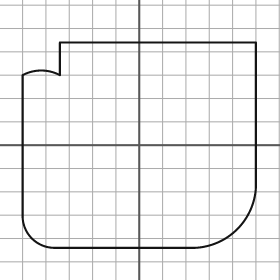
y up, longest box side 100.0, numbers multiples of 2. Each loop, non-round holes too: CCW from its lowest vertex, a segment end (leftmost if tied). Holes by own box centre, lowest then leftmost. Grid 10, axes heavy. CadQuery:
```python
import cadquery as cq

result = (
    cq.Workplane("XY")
    .moveTo(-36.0, -44.0)
    .lineTo(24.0, -44.0)
    .threePointArc((42.0, -36.0), (50.0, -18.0))
    .lineTo(50.0, 44.0)
    .lineTo(-34.0, 44.0)
    .lineTo(-34.0, 30.0)
    .threePointArc((-42.0, 32.0), (-50.0, 30.0))
    .lineTo(-50.0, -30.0)
    .threePointArc((-46.0, -40.0), (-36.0, -44.0))
    .close()
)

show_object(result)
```